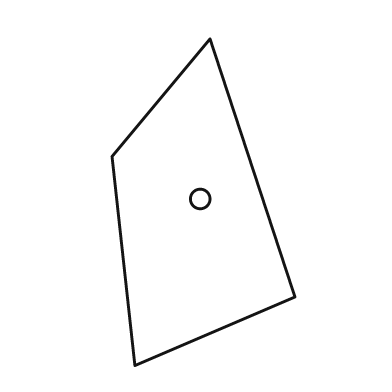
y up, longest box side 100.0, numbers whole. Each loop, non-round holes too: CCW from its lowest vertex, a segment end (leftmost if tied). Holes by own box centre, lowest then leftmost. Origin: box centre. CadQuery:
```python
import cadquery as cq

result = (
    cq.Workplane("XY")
    .moveTo(-21.0, -50.0)
    .lineTo(28.0, -29.0)
    .lineTo(2.0, 50.0)
    .lineTo(-28.0, 14.0)
    .close()
    .moveTo(-1.0, 1.0)
    .circle(3.0)
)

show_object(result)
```